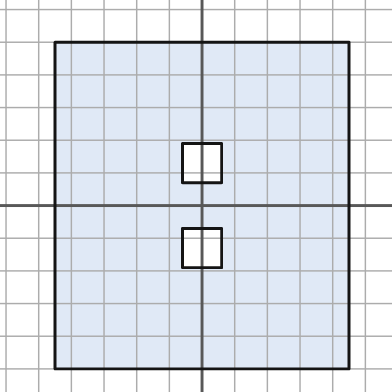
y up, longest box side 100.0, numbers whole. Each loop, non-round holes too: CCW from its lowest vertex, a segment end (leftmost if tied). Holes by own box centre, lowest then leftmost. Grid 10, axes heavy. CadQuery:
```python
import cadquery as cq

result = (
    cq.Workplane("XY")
    .moveTo(-45.0, -50.0)
    .lineTo(45.0, -50.0)
    .lineTo(45.0, 50.0)
    .lineTo(-45.0, 50.0)
    .close()
    .moveTo(-6.0, -19.0)
    .lineTo(6.0, -19.0)
    .lineTo(6.0, -7.0)
    .lineTo(-6.0, -7.0)
    .close()
    .moveTo(-6.0, 7.0)
    .lineTo(6.0, 7.0)
    .lineTo(6.0, 19.0)
    .lineTo(-6.0, 19.0)
    .close()
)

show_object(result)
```